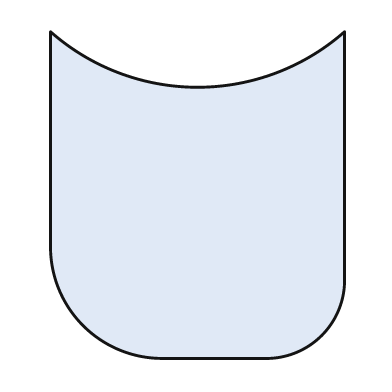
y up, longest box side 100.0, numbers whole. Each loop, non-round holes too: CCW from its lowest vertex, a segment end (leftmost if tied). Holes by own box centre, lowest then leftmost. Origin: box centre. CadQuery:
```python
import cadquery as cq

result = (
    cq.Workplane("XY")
    .moveTo(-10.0, -50.0)
    .lineTo(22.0, -50.0)
    .threePointArc((38.0, -43.0), (45.0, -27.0))
    .lineTo(45.0, 50.0)
    .threePointArc((0.0, 33.0), (-45.0, 50.0))
    .lineTo(-45.0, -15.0)
    .threePointArc((-35.0, -40.0), (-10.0, -50.0))
    .close()
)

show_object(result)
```